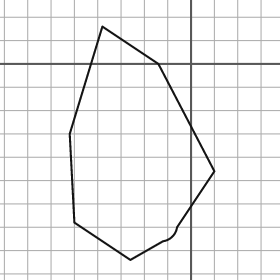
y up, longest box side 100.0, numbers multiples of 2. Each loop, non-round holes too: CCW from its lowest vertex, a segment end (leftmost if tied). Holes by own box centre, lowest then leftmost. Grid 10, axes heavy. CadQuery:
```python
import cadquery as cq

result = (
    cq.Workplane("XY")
    .moveTo(-26.0, -84.0)
    .lineTo(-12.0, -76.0)
    .threePointArc((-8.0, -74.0), (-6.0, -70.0))
    .lineTo(10.0, -46.0)
    .lineTo(-14.0, 0.0)
    .lineTo(-38.0, 16.0)
    .lineTo(-52.0, -30.0)
    .lineTo(-50.0, -68.0)
    .close()
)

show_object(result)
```